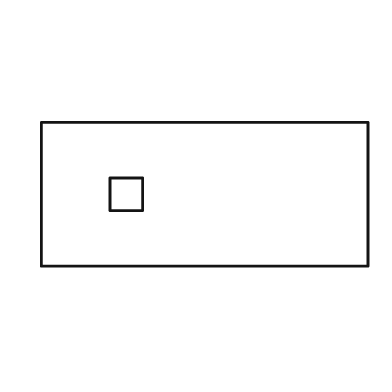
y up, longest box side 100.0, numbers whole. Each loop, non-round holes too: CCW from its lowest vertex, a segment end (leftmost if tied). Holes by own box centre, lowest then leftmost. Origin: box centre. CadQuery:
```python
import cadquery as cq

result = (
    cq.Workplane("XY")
    .moveTo(-50.0, -22.0)
    .lineTo(50.0, -22.0)
    .lineTo(50.0, 22.0)
    .lineTo(-50.0, 22.0)
    .close()
    .moveTo(-29.0, -5.0)
    .lineTo(-19.0, -5.0)
    .lineTo(-19.0, 5.0)
    .lineTo(-29.0, 5.0)
    .close()
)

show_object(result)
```